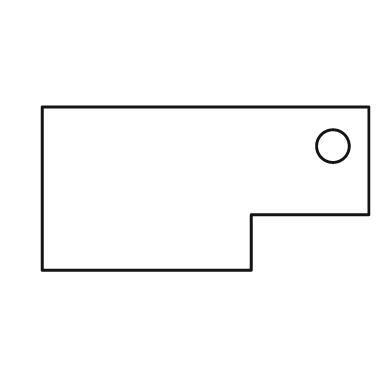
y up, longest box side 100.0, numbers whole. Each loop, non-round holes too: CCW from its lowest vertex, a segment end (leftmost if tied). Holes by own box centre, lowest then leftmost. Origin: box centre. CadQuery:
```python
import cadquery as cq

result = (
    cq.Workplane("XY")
    .moveTo(-50.0, -25.0)
    .lineTo(14.0, -25.0)
    .lineTo(14.0, -8.0)
    .lineTo(50.0, -8.0)
    .lineTo(50.0, 25.0)
    .lineTo(-50.0, 25.0)
    .close()
    .moveTo(39.0, 13.0)
    .circle(5.0)
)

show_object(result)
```